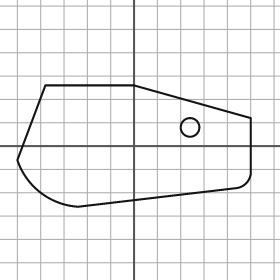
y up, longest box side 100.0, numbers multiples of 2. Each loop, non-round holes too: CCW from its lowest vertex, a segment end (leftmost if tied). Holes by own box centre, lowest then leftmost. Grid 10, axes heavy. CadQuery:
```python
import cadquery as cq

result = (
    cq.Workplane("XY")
    .moveTo(-24.0, -26.0)
    .lineTo(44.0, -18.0)
    .threePointArc((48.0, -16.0), (50.0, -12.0))
    .lineTo(50.0, 12.0)
    .lineTo(0.0, 26.0)
    .lineTo(-38.0, 26.0)
    .lineTo(-50.0, -6.0)
    .threePointArc((-40.0, -20.0), (-24.0, -26.0))
    .close()
    .moveTo(24.0, 8.0)
    .circle(4.0)
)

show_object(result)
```